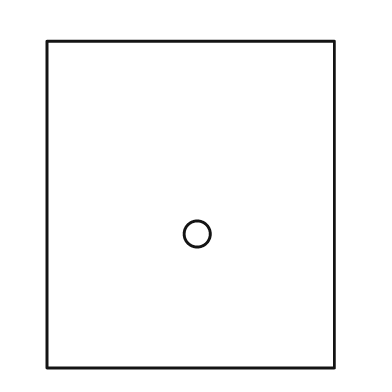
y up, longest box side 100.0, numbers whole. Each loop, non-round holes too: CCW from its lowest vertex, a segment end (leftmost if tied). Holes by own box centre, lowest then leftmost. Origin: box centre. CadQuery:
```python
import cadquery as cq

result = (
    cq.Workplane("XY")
    .moveTo(-44.0, -50.0)
    .lineTo(44.0, -50.0)
    .lineTo(44.0, 50.0)
    .lineTo(-44.0, 50.0)
    .close()
    .moveTo(2.0, -9.0)
    .circle(4.0)
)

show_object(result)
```